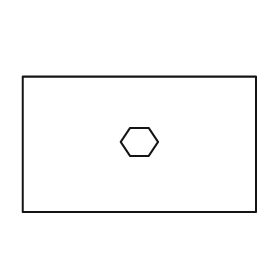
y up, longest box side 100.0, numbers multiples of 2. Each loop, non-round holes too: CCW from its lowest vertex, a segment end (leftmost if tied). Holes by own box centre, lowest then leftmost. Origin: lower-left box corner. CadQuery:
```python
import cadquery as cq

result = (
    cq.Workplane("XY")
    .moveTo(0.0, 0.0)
    .lineTo(100.0, 0.0)
    .lineTo(100.0, 58.0)
    .lineTo(0.0, 58.0)
    .close()
    .moveTo(46.0, 24.0)
    .lineTo(54.0, 24.0)
    .lineTo(58.0, 30.0)
    .lineTo(54.0, 36.0)
    .lineTo(46.0, 36.0)
    .lineTo(42.0, 30.0)
    .close()
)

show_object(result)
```